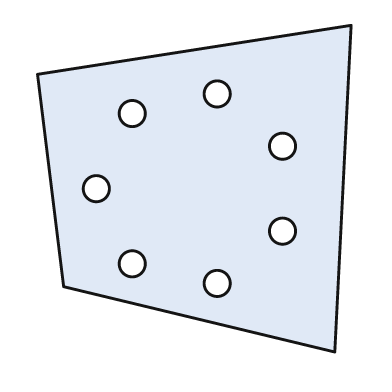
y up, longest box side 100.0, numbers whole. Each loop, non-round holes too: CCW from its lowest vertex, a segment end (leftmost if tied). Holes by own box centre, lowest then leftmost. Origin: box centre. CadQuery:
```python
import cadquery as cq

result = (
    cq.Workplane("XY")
    .moveTo(43.0, -50.0)
    .lineTo(48.0, 50.0)
    .lineTo(-48.0, 35.0)
    .lineTo(-40.0, -30.0)
    .close()
    .moveTo(7.0, -29.0)
    .circle(4.0)
    .moveTo(-19.0, -23.0)
    .circle(4.0)
    .moveTo(27.0, -13.0)
    .circle(4.0)
    .moveTo(-30.0, 0.0)
    .circle(4.0)
    .moveTo(27.0, 13.0)
    .circle(4.0)
    .moveTo(-19.0, 23.0)
    .circle(4.0)
    .moveTo(7.0, 29.0)
    .circle(4.0)
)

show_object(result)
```